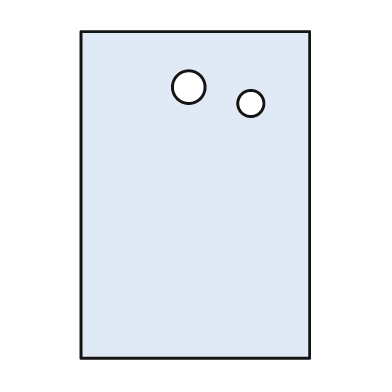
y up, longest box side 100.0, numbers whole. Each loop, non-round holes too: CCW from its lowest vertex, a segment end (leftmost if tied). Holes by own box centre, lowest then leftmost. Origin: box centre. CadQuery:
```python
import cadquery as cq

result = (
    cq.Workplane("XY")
    .moveTo(-35.0, -50.0)
    .lineTo(35.0, -50.0)
    .lineTo(35.0, 50.0)
    .lineTo(-35.0, 50.0)
    .close()
    .moveTo(17.0, 28.0)
    .circle(4.0)
    .moveTo(-2.0, 33.0)
    .circle(5.0)
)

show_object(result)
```